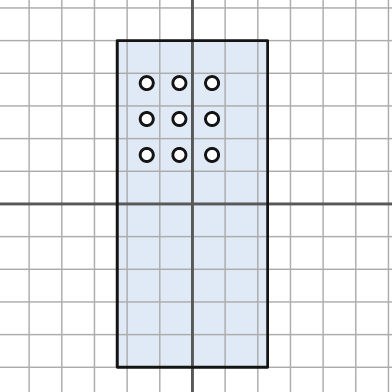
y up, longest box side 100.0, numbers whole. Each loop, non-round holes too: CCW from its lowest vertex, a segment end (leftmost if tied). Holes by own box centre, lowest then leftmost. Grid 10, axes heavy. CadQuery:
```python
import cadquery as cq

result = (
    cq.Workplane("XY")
    .moveTo(-23.0, -50.0)
    .lineTo(23.0, -50.0)
    .lineTo(23.0, 50.0)
    .lineTo(-23.0, 50.0)
    .close()
    .moveTo(-14.0, 15.0)
    .circle(2.0)
    .moveTo(-4.0, 15.0)
    .circle(2.0)
    .moveTo(6.0, 15.0)
    .circle(2.0)
    .moveTo(-14.0, 26.0)
    .circle(2.0)
    .moveTo(-4.0, 26.0)
    .circle(2.0)
    .moveTo(6.0, 26.0)
    .circle(2.0)
    .moveTo(-14.0, 37.0)
    .circle(2.0)
    .moveTo(-4.0, 37.0)
    .circle(2.0)
    .moveTo(6.0, 37.0)
    .circle(2.0)
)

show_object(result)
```